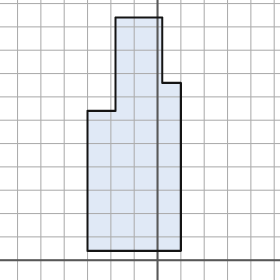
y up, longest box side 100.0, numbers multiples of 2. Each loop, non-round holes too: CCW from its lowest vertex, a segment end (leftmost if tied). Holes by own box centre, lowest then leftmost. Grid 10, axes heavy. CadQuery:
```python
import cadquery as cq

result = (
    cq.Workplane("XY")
    .moveTo(-30.0, 4.0)
    .lineTo(10.0, 4.0)
    .lineTo(10.0, 76.0)
    .lineTo(2.0, 76.0)
    .lineTo(2.0, 104.0)
    .lineTo(-18.0, 104.0)
    .lineTo(-18.0, 64.0)
    .lineTo(-30.0, 64.0)
    .close()
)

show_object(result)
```